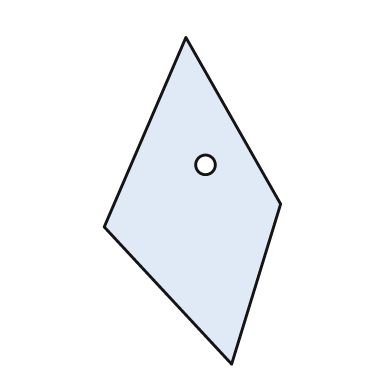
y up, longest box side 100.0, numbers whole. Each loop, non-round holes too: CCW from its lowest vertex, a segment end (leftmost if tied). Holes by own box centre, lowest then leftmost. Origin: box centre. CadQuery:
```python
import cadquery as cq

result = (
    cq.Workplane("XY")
    .moveTo(12.0, -50.0)
    .lineTo(27.0, -1.0)
    .lineTo(-2.0, 50.0)
    .lineTo(-27.0, -8.0)
    .close()
    .moveTo(4.0, 11.0)
    .circle(3.0)
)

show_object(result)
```